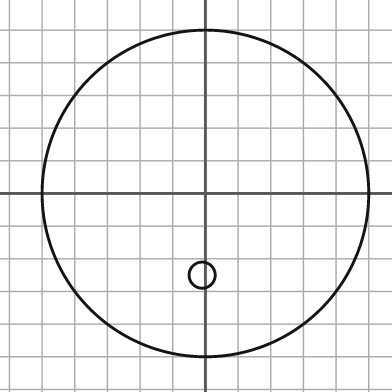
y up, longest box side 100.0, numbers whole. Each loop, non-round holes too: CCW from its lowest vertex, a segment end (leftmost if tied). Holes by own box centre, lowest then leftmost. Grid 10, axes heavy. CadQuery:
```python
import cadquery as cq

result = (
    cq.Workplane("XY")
    .moveTo(0.0, 0.0)
    .circle(50.0)
    .moveTo(-1.0, -25.0)
    .circle(4.0)
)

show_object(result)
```